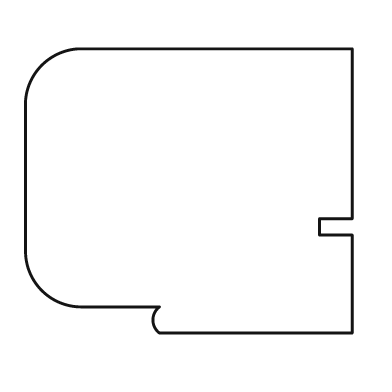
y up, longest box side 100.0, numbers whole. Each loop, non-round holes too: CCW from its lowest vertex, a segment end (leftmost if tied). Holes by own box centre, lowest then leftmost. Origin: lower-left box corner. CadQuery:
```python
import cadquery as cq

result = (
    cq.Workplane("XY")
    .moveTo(41.0, 0.0)
    .lineTo(100.0, 0.0)
    .lineTo(100.0, 30.0)
    .lineTo(90.0, 30.0)
    .lineTo(90.0, 35.0)
    .lineTo(100.0, 35.0)
    .lineTo(100.0, 87.0)
    .lineTo(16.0, 87.0)
    .threePointArc((5.0, 82.0), (0.0, 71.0))
    .lineTo(0.0, 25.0)
    .threePointArc((5.0, 13.0), (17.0, 8.0))
    .lineTo(41.0, 8.0)
    .threePointArc((39.0, 4.0), (41.0, 0.0))
    .close()
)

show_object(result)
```